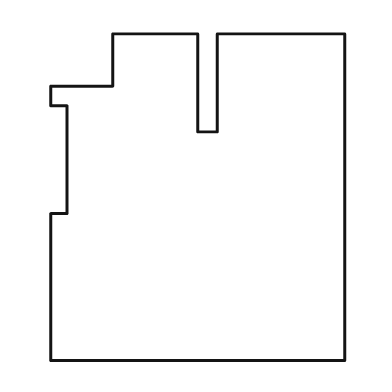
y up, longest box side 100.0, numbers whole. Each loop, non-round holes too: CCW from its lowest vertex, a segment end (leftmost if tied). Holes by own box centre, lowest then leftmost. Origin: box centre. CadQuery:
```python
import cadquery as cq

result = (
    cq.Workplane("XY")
    .moveTo(-45.0, -50.0)
    .lineTo(45.0, -50.0)
    .lineTo(45.0, 50.0)
    .lineTo(6.0, 50.0)
    .lineTo(6.0, 20.0)
    .lineTo(0.0, 20.0)
    .lineTo(0.0, 50.0)
    .lineTo(-26.0, 50.0)
    .lineTo(-26.0, 34.0)
    .lineTo(-45.0, 34.0)
    .lineTo(-45.0, 28.0)
    .lineTo(-40.0, 28.0)
    .lineTo(-40.0, -5.0)
    .lineTo(-45.0, -5.0)
    .close()
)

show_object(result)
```